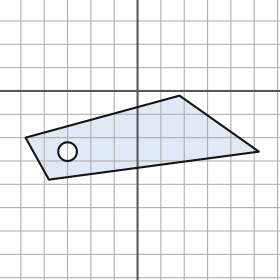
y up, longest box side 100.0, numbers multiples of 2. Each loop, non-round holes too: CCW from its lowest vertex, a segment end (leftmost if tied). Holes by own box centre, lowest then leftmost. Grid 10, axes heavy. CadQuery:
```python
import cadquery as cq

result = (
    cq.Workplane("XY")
    .moveTo(-38.0, -38.0)
    .lineTo(52.0, -26.0)
    .lineTo(18.0, -2.0)
    .lineTo(-48.0, -20.0)
    .close()
    .moveTo(-30.0, -26.0)
    .circle(4.0)
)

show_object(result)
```